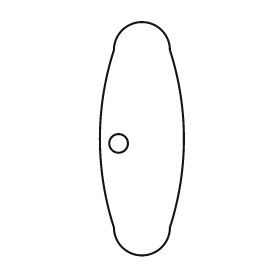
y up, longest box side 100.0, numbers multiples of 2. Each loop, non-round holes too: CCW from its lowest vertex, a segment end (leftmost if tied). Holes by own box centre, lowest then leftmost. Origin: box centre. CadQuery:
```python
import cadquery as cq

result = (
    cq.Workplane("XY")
    .moveTo(-12.0, -38.0)
    .threePointArc((0.0, -50.0), (12.0, -38.0))
    .threePointArc((18.0, 0.0), (12.0, 38.0))
    .threePointArc((0.0, 50.0), (-12.0, 38.0))
    .threePointArc((-18.0, 0.0), (-12.0, -38.0))
    .close()
    .moveTo(-10.0, -2.0)
    .circle(4.0)
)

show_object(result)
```